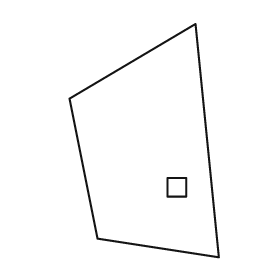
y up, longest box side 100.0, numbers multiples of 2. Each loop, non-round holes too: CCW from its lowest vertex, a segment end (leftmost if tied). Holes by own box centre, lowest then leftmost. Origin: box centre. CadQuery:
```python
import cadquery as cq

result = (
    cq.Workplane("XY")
    .moveTo(32.0, -50.0)
    .lineTo(22.0, 50.0)
    .lineTo(-32.0, 18.0)
    .lineTo(-20.0, -42.0)
    .close()
    .moveTo(10.0, -24.0)
    .lineTo(18.0, -24.0)
    .lineTo(18.0, -16.0)
    .lineTo(10.0, -16.0)
    .close()
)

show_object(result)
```